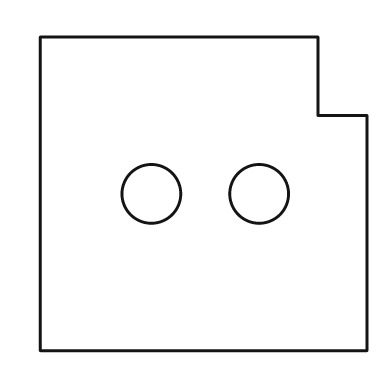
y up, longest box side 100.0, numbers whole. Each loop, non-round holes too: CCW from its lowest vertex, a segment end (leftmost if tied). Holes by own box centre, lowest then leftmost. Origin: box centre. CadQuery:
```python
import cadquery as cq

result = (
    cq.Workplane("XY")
    .moveTo(-50.0, -48.0)
    .lineTo(50.0, -48.0)
    .lineTo(50.0, 24.0)
    .lineTo(35.0, 24.0)
    .lineTo(35.0, 48.0)
    .lineTo(-50.0, 48.0)
    .close()
    .moveTo(-16.0, 0.0)
    .circle(9.0)
    .moveTo(17.0, 0.0)
    .circle(9.0)
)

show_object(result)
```